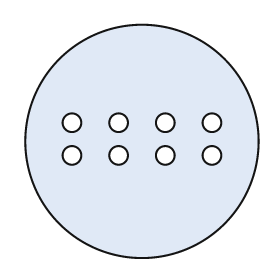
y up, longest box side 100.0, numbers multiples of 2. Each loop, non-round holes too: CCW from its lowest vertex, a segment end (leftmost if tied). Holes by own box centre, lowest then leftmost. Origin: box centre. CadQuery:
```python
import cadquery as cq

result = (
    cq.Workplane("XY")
    .moveTo(0.0, 0.0)
    .circle(50.0)
    .moveTo(-30.0, -6.0)
    .circle(4.0)
    .moveTo(-10.0, -6.0)
    .circle(4.0)
    .moveTo(10.0, -6.0)
    .circle(4.0)
    .moveTo(30.0, -6.0)
    .circle(4.0)
    .moveTo(-30.0, 8.0)
    .circle(4.0)
    .moveTo(-10.0, 8.0)
    .circle(4.0)
    .moveTo(10.0, 8.0)
    .circle(4.0)
    .moveTo(30.0, 8.0)
    .circle(4.0)
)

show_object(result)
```